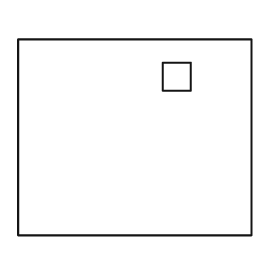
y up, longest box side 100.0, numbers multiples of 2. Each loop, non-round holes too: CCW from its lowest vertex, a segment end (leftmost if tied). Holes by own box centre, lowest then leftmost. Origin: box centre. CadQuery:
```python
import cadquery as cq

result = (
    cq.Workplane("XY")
    .moveTo(-50.0, -42.0)
    .lineTo(50.0, -42.0)
    .lineTo(50.0, 42.0)
    .lineTo(-50.0, 42.0)
    .close()
    .moveTo(12.0, 20.0)
    .lineTo(24.0, 20.0)
    .lineTo(24.0, 32.0)
    .lineTo(12.0, 32.0)
    .close()
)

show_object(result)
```